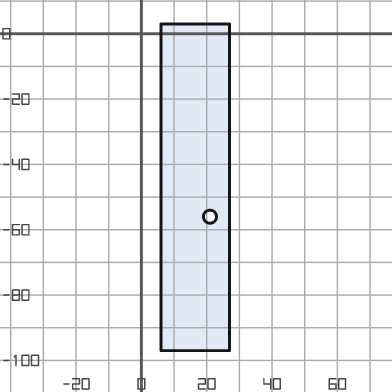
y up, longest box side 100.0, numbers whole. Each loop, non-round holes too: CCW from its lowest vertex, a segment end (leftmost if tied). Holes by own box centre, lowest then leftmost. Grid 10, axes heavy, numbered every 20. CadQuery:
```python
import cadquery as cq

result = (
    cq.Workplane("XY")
    .moveTo(6.0, -97.0)
    .lineTo(27.0, -97.0)
    .lineTo(27.0, 3.0)
    .lineTo(6.0, 3.0)
    .close()
    .moveTo(21.0, -56.0)
    .circle(2.0)
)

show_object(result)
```